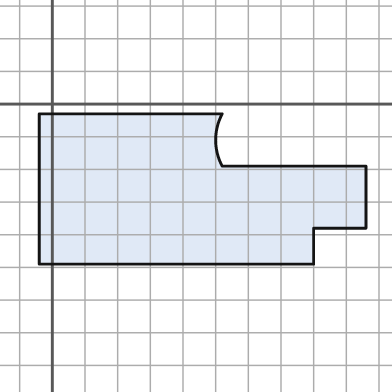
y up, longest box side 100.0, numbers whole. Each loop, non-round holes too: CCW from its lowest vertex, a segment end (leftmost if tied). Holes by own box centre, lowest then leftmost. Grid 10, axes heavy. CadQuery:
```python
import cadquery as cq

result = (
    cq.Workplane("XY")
    .moveTo(-4.0, -49.0)
    .lineTo(80.0, -49.0)
    .lineTo(80.0, -38.0)
    .lineTo(96.0, -38.0)
    .lineTo(96.0, -19.0)
    .lineTo(52.0, -19.0)
    .threePointArc((50.0, -11.0), (52.0, -3.0))
    .lineTo(-4.0, -3.0)
    .close()
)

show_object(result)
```